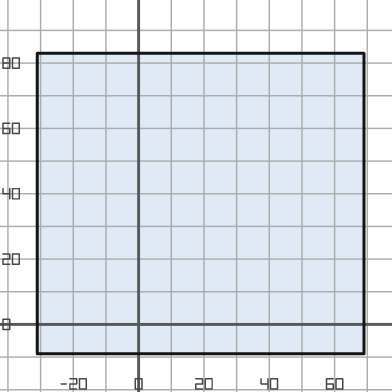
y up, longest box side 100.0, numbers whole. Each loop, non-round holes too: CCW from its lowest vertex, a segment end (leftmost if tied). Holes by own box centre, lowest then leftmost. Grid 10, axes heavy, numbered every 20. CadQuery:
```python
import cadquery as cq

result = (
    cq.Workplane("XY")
    .moveTo(-31.0, -9.0)
    .lineTo(69.0, -9.0)
    .lineTo(69.0, 83.0)
    .lineTo(-31.0, 83.0)
    .close()
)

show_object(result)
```